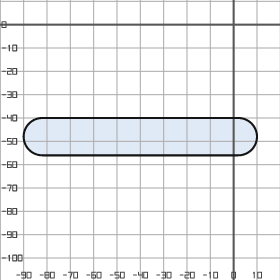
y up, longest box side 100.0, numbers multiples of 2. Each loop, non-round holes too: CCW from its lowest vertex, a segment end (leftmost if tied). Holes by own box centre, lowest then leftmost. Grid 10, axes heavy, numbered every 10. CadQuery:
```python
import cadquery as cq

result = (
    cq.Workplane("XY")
    .moveTo(-82.0, -56.0)
    .lineTo(2.0, -56.0)
    .threePointArc((10.0, -48.0), (2.0, -40.0))
    .lineTo(-82.0, -40.0)
    .threePointArc((-90.0, -48.0), (-82.0, -56.0))
    .close()
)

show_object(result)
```